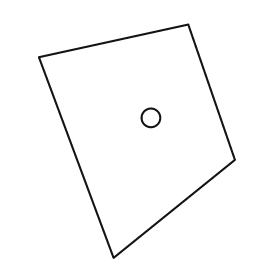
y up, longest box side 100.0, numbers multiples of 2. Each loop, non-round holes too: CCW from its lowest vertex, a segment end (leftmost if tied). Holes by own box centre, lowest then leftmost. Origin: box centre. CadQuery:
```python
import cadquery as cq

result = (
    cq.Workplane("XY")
    .moveTo(-10.0, -50.0)
    .lineTo(42.0, -8.0)
    .lineTo(22.0, 50.0)
    .lineTo(-42.0, 36.0)
    .close()
    .moveTo(6.0, 10.0)
    .circle(4.0)
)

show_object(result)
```